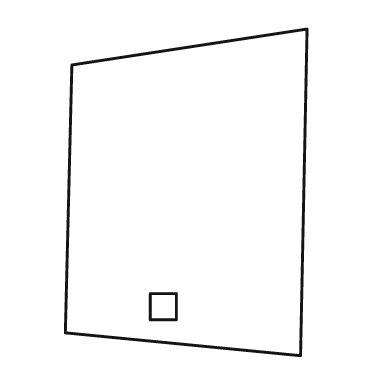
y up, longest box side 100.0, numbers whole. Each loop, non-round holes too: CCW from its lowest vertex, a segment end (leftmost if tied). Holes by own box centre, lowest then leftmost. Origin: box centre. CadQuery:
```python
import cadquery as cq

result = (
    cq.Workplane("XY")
    .moveTo(35.0, -50.0)
    .lineTo(37.0, 50.0)
    .lineTo(-35.0, 39.0)
    .lineTo(-37.0, -43.0)
    .close()
    .moveTo(-11.0, -39.0)
    .lineTo(-3.0, -39.0)
    .lineTo(-3.0, -31.0)
    .lineTo(-11.0, -31.0)
    .close()
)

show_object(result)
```